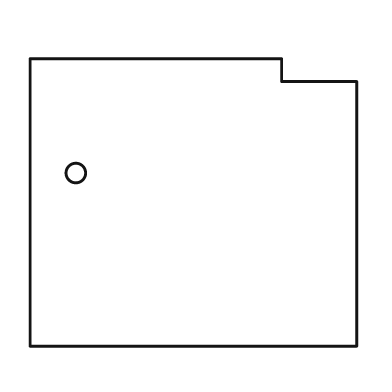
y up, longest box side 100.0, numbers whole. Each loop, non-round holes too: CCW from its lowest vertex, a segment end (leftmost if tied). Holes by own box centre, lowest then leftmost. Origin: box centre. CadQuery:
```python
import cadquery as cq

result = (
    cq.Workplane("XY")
    .moveTo(-50.0, -44.0)
    .lineTo(50.0, -44.0)
    .lineTo(50.0, 37.0)
    .lineTo(27.0, 37.0)
    .lineTo(27.0, 44.0)
    .lineTo(-50.0, 44.0)
    .close()
    .moveTo(-36.0, 9.0)
    .circle(3.0)
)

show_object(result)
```